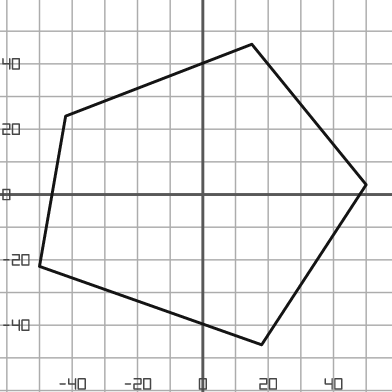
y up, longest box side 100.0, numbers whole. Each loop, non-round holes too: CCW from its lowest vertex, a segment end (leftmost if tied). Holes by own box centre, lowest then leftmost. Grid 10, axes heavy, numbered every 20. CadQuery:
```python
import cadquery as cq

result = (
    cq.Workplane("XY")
    .moveTo(18.0, -46.0)
    .lineTo(50.0, 3.0)
    .lineTo(15.0, 46.0)
    .lineTo(-42.0, 24.0)
    .lineTo(-50.0, -22.0)
    .close()
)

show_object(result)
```